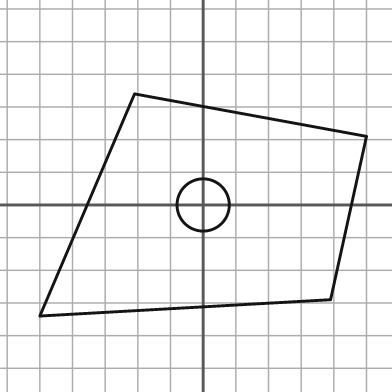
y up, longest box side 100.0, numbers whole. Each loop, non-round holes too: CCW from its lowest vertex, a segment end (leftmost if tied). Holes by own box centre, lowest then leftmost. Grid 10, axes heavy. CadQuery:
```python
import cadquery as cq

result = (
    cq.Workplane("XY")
    .moveTo(-50.0, -34.0)
    .lineTo(39.0, -29.0)
    .lineTo(50.0, 21.0)
    .lineTo(-21.0, 34.0)
    .close()
    .moveTo(0.0, 0.0)
    .circle(8.0)
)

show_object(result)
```